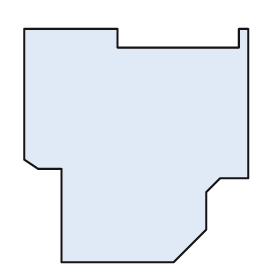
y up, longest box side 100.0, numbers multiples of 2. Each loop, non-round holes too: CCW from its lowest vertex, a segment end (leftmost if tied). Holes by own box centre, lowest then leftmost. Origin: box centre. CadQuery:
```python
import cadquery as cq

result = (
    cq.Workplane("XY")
    .moveTo(-32.0, -50.0)
    .lineTo(16.0, -50.0)
    .lineTo(30.0, -36.0)
    .lineTo(30.0, -20.0)
    .lineTo(36.0, -14.0)
    .lineTo(48.0, -14.0)
    .lineTo(48.0, 50.0)
    .lineTo(44.0, 50.0)
    .lineTo(44.0, 42.0)
    .lineTo(-8.0, 42.0)
    .lineTo(-8.0, 50.0)
    .lineTo(-48.0, 50.0)
    .lineTo(-48.0, -6.0)
    .lineTo(-42.0, -10.0)
    .lineTo(-32.0, -10.0)
    .close()
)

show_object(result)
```